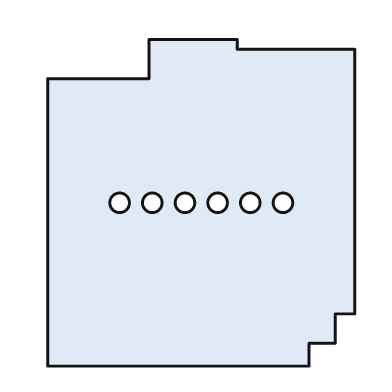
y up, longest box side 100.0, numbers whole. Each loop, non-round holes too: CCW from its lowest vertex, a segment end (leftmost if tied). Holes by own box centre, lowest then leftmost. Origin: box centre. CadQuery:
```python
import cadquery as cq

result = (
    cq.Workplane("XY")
    .moveTo(-47.0, -50.0)
    .lineTo(33.0, -50.0)
    .lineTo(33.0, -43.0)
    .lineTo(41.0, -43.0)
    .lineTo(41.0, -34.0)
    .lineTo(47.0, -34.0)
    .lineTo(47.0, 47.0)
    .lineTo(11.0, 47.0)
    .lineTo(11.0, 50.0)
    .lineTo(-16.0, 50.0)
    .lineTo(-16.0, 38.0)
    .lineTo(-47.0, 38.0)
    .close()
    .moveTo(-25.0, 0.0)
    .circle(3.0)
    .moveTo(-15.0, 0.0)
    .circle(3.0)
    .moveTo(-5.0, 0.0)
    .circle(3.0)
    .moveTo(5.0, 0.0)
    .circle(3.0)
    .moveTo(15.0, 0.0)
    .circle(3.0)
    .moveTo(25.0, 0.0)
    .circle(3.0)
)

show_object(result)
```